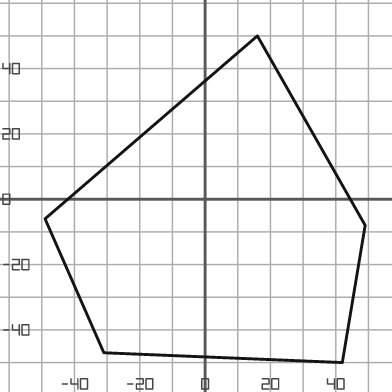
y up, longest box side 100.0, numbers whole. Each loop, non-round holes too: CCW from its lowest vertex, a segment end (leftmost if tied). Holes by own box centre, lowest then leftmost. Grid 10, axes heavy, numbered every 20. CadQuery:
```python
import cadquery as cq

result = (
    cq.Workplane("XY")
    .moveTo(42.0, -50.0)
    .lineTo(49.0, -8.0)
    .lineTo(16.0, 50.0)
    .lineTo(-49.0, -6.0)
    .lineTo(-31.0, -47.0)
    .close()
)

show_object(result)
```